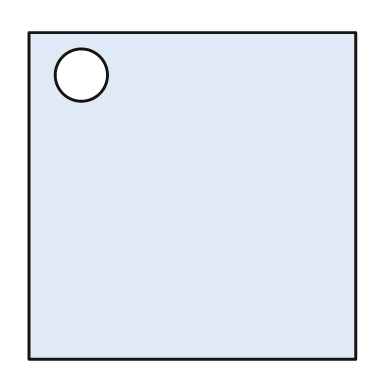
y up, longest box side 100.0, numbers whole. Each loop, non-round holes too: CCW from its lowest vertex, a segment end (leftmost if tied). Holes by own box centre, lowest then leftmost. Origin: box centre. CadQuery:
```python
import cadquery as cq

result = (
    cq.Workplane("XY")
    .moveTo(-50.0, -50.0)
    .lineTo(50.0, -50.0)
    .lineTo(50.0, 50.0)
    .lineTo(-50.0, 50.0)
    .close()
    .moveTo(-34.0, 37.0)
    .circle(8.0)
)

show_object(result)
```